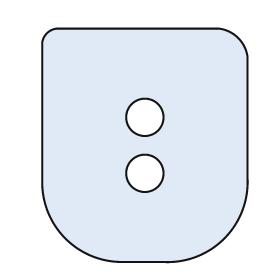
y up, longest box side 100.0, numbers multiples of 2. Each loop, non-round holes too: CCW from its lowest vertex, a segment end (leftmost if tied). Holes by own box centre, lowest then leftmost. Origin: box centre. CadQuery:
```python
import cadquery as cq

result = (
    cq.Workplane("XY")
    .moveTo(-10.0, -50.0)
    .lineTo(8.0, -50.0)
    .threePointArc((34.0, -40.0), (44.0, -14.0))
    .lineTo(44.0, 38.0)
    .threePointArc((40.0, 46.0), (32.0, 50.0))
    .lineTo(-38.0, 50.0)
    .threePointArc((-42.0, 48.0), (-44.0, 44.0))
    .lineTo(-44.0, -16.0)
    .threePointArc((-34.0, -40.0), (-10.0, -50.0))
    .close()
    .moveTo(0.0, -12.0)
    .circle(8.0)
    .moveTo(0.0, 12.0)
    .circle(8.0)
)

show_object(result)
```